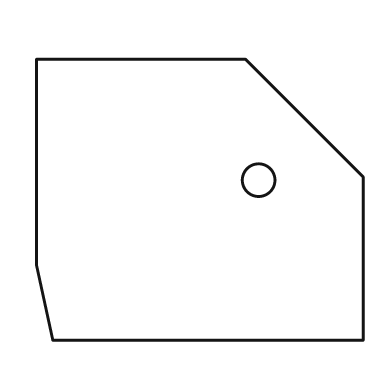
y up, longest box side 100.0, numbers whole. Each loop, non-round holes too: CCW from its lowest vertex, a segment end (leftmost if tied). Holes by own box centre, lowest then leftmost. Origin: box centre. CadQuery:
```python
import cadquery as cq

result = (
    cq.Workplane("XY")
    .moveTo(-45.0, -43.0)
    .lineTo(50.0, -43.0)
    .lineTo(50.0, 7.0)
    .lineTo(14.0, 43.0)
    .lineTo(-50.0, 43.0)
    .lineTo(-50.0, -20.0)
    .close()
    .moveTo(18.0, 6.0)
    .circle(5.0)
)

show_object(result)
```